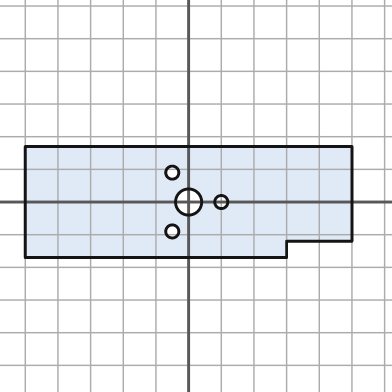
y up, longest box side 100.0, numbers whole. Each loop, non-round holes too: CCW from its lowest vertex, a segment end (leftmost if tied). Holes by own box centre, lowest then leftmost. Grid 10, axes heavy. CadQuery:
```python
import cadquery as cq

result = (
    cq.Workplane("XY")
    .moveTo(-50.0, -17.0)
    .lineTo(30.0, -17.0)
    .lineTo(30.0, -12.0)
    .lineTo(50.0, -12.0)
    .lineTo(50.0, 17.0)
    .lineTo(-50.0, 17.0)
    .close()
    .moveTo(-5.0, -9.0)
    .circle(2.0)
    .moveTo(0.0, 0.0)
    .circle(4.0)
    .moveTo(10.0, 0.0)
    .circle(2.0)
    .moveTo(-5.0, 9.0)
    .circle(2.0)
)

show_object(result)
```